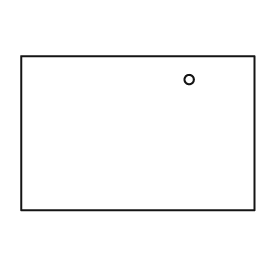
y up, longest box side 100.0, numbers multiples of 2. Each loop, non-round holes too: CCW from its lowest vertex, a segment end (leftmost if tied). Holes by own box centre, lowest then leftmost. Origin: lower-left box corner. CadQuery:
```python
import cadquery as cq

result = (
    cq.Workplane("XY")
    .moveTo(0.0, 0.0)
    .lineTo(100.0, 0.0)
    .lineTo(100.0, 66.0)
    .lineTo(0.0, 66.0)
    .close()
    .moveTo(72.0, 56.0)
    .circle(2.0)
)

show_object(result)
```